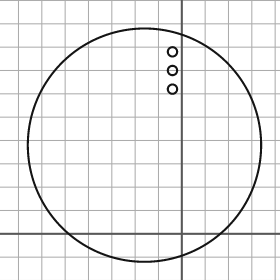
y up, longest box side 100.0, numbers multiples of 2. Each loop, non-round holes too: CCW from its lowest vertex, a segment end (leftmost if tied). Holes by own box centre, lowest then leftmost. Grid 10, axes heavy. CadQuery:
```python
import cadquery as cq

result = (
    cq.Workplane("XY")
    .moveTo(-16.0, 38.0)
    .circle(50.0)
    .moveTo(-4.0, 62.0)
    .circle(2.0)
    .moveTo(-4.0, 70.0)
    .circle(2.0)
    .moveTo(-4.0, 78.0)
    .circle(2.0)
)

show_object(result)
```